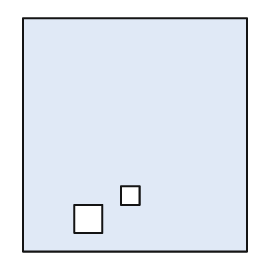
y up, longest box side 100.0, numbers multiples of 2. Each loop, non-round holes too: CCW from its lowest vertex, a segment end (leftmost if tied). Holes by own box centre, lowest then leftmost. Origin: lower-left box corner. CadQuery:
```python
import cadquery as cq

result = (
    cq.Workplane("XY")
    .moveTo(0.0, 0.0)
    .lineTo(96.0, 0.0)
    .lineTo(96.0, 100.0)
    .lineTo(0.0, 100.0)
    .close()
    .moveTo(22.0, 8.0)
    .lineTo(34.0, 8.0)
    .lineTo(34.0, 20.0)
    .lineTo(22.0, 20.0)
    .close()
    .moveTo(42.0, 20.0)
    .lineTo(50.0, 20.0)
    .lineTo(50.0, 28.0)
    .lineTo(42.0, 28.0)
    .close()
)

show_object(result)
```